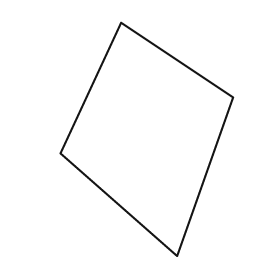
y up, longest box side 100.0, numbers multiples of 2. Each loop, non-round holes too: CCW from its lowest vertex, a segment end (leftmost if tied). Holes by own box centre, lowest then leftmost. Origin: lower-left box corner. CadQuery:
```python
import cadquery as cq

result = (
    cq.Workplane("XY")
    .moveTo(50.0, 0.0)
    .lineTo(74.0, 68.0)
    .lineTo(26.0, 100.0)
    .lineTo(0.0, 44.0)
    .close()
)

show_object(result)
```